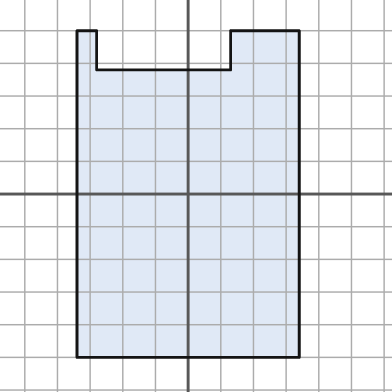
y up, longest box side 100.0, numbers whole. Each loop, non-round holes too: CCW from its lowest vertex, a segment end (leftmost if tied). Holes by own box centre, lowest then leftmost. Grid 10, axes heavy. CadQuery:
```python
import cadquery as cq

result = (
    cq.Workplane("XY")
    .moveTo(-34.0, -50.0)
    .lineTo(34.0, -50.0)
    .lineTo(34.0, 50.0)
    .lineTo(13.0, 50.0)
    .lineTo(13.0, 38.0)
    .lineTo(-28.0, 38.0)
    .lineTo(-28.0, 50.0)
    .lineTo(-34.0, 50.0)
    .close()
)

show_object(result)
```